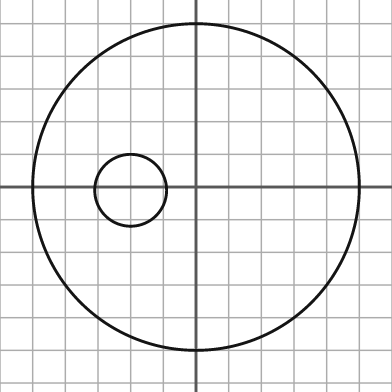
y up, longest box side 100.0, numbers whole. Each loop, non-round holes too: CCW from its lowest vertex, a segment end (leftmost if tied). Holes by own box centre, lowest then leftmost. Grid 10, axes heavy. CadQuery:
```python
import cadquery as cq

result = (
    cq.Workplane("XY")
    .moveTo(0.0, 0.0)
    .circle(50.0)
    .moveTo(-20.0, -1.0)
    .circle(11.0)
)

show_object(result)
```